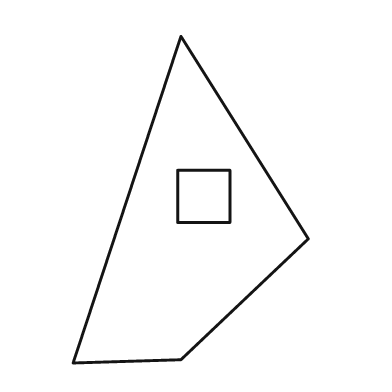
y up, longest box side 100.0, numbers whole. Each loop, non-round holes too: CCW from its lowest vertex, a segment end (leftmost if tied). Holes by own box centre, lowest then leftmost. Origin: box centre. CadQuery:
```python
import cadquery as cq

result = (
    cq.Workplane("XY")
    .moveTo(-36.0, -50.0)
    .lineTo(-3.0, -49.0)
    .lineTo(36.0, -12.0)
    .lineTo(-3.0, 50.0)
    .close()
    .moveTo(-4.0, -7.0)
    .lineTo(12.0, -7.0)
    .lineTo(12.0, 9.0)
    .lineTo(-4.0, 9.0)
    .close()
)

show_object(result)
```